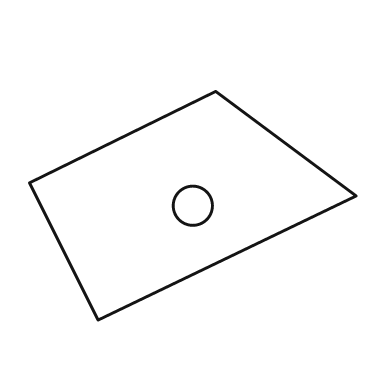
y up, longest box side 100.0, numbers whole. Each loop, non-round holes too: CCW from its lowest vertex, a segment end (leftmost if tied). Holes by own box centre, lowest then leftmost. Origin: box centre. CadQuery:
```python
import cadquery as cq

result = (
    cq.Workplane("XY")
    .moveTo(-29.0, -35.0)
    .lineTo(50.0, 3.0)
    .lineTo(7.0, 35.0)
    .lineTo(-50.0, 7.0)
    .close()
    .moveTo(0.0, 0.0)
    .circle(6.0)
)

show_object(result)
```